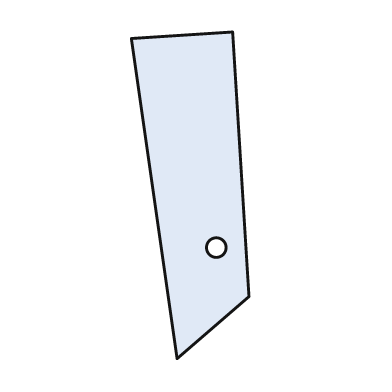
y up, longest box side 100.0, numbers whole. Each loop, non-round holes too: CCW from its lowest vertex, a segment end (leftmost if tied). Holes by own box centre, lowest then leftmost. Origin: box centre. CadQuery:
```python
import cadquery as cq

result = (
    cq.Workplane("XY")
    .moveTo(-4.0, -50.0)
    .lineTo(18.0, -31.0)
    .lineTo(13.0, 50.0)
    .lineTo(-18.0, 48.0)
    .close()
    .moveTo(8.0, -16.0)
    .circle(3.0)
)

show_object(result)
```